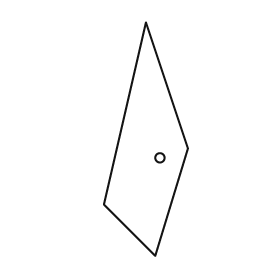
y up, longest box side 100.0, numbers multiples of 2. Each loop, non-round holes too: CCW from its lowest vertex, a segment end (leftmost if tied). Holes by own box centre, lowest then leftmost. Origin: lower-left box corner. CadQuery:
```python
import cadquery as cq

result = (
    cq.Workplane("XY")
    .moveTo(22.0, 0.0)
    .lineTo(36.0, 46.0)
    .lineTo(18.0, 100.0)
    .lineTo(0.0, 22.0)
    .close()
    .moveTo(24.0, 42.0)
    .circle(2.0)
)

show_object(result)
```